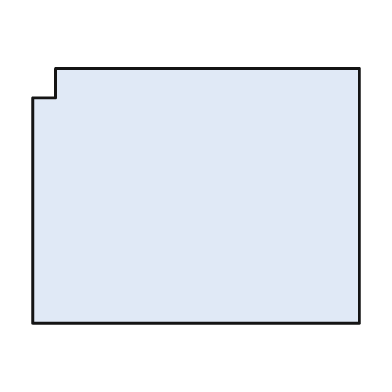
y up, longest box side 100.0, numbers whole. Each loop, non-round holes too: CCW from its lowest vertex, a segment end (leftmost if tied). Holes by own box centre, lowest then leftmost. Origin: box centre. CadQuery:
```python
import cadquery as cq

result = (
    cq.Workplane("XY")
    .moveTo(-50.0, -39.0)
    .lineTo(50.0, -39.0)
    .lineTo(50.0, 39.0)
    .lineTo(-43.0, 39.0)
    .lineTo(-43.0, 30.0)
    .lineTo(-50.0, 30.0)
    .close()
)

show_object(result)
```